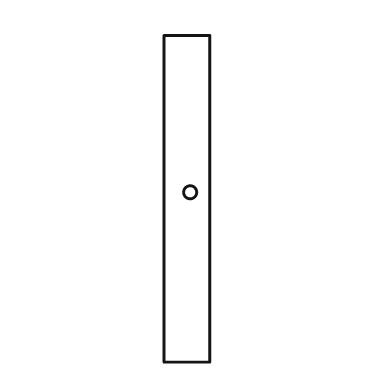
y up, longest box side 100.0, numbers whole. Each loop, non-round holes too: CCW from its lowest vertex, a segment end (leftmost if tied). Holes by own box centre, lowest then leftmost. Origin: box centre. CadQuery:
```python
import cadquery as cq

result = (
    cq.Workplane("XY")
    .moveTo(-7.0, -50.0)
    .lineTo(7.0, -50.0)
    .lineTo(7.0, 50.0)
    .lineTo(-7.0, 50.0)
    .close()
    .moveTo(1.0, 2.0)
    .circle(2.0)
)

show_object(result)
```